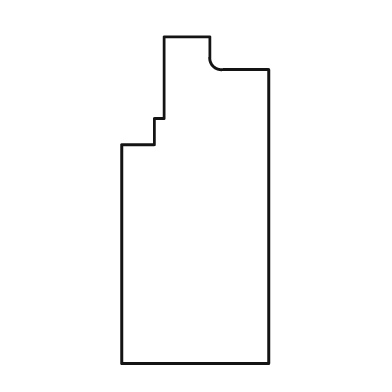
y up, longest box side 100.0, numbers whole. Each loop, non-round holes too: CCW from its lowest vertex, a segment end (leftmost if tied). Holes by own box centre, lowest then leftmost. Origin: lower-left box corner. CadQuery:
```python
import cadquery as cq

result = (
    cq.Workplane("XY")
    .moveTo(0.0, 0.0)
    .lineTo(45.0, 0.0)
    .lineTo(45.0, 90.0)
    .lineTo(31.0, 90.0)
    .threePointArc((28.0, 91.0), (27.0, 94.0))
    .lineTo(27.0, 100.0)
    .lineTo(13.0, 100.0)
    .lineTo(13.0, 75.0)
    .lineTo(10.0, 75.0)
    .lineTo(10.0, 67.0)
    .lineTo(0.0, 67.0)
    .close()
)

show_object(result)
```